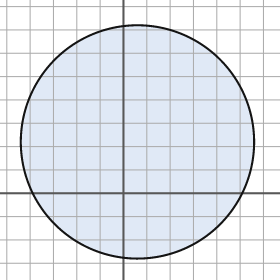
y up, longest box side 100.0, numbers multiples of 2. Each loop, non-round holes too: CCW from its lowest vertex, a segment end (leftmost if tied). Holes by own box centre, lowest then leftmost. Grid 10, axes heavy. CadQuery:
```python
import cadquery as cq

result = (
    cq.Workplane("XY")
    .moveTo(6.0, 22.0)
    .circle(50.0)
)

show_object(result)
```